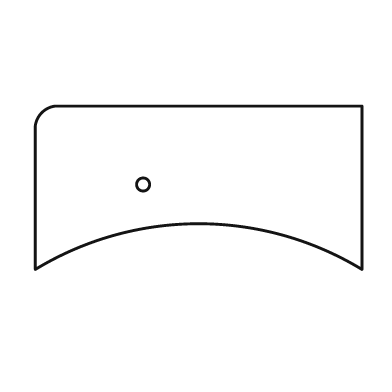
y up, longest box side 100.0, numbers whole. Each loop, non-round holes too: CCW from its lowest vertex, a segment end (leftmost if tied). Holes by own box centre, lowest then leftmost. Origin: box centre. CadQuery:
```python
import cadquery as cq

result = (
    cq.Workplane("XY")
    .moveTo(-50.0, -25.0)
    .threePointArc((0.0, -11.0), (50.0, -25.0))
    .lineTo(50.0, 25.0)
    .lineTo(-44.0, 25.0)
    .threePointArc((-48.0, 23.0), (-50.0, 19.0))
    .close()
    .moveTo(-17.0, 1.0)
    .circle(2.0)
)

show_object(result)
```